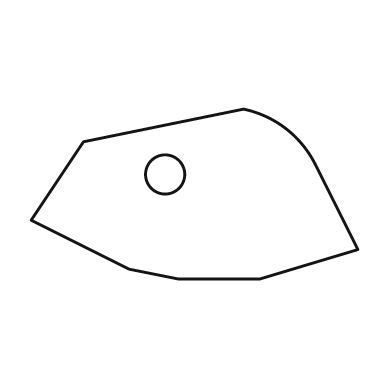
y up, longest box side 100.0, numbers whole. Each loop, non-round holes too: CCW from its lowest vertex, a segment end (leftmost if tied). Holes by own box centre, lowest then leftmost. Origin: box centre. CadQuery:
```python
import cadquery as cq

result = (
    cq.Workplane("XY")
    .moveTo(-5.0, -26.0)
    .lineTo(20.0, -26.0)
    .lineTo(50.0, -17.0)
    .lineTo(37.0, 9.0)
    .threePointArc((28.0, 20.0), (15.0, 26.0))
    .lineTo(-34.0, 16.0)
    .lineTo(-50.0, -8.0)
    .lineTo(-20.0, -23.0)
    .close()
    .moveTo(-9.0, 6.0)
    .circle(6.0)
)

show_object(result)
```